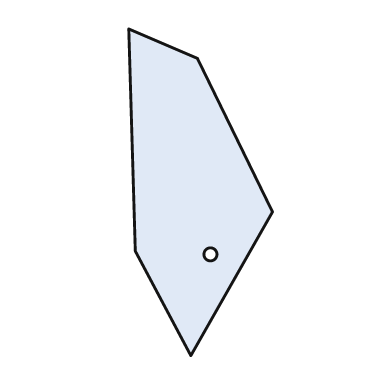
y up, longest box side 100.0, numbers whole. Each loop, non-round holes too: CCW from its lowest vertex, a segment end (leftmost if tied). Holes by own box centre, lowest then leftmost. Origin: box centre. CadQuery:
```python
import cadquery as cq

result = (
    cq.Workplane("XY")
    .moveTo(-3.0, -50.0)
    .lineTo(22.0, -6.0)
    .lineTo(-1.0, 41.0)
    .lineTo(-22.0, 50.0)
    .lineTo(-20.0, -18.0)
    .close()
    .moveTo(3.0, -19.0)
    .circle(2.0)
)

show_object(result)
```